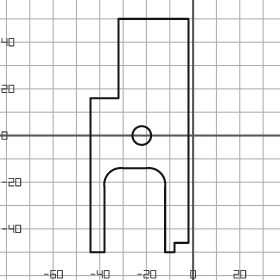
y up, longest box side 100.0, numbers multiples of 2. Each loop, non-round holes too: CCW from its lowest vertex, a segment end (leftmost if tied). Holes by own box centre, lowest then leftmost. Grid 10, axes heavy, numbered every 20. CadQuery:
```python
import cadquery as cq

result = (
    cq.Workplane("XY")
    .moveTo(-44.0, -50.0)
    .lineTo(-38.0, -50.0)
    .lineTo(-38.0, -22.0)
    .threePointArc((-36.0, -16.0), (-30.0, -14.0))
    .lineTo(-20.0, -14.0)
    .threePointArc((-14.0, -16.0), (-12.0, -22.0))
    .lineTo(-12.0, -50.0)
    .lineTo(-8.0, -50.0)
    .lineTo(-8.0, -46.0)
    .lineTo(-2.0, -46.0)
    .lineTo(-2.0, 50.0)
    .lineTo(-32.0, 50.0)
    .lineTo(-32.0, 16.0)
    .lineTo(-44.0, 16.0)
    .close()
    .moveTo(-22.0, 0.0)
    .circle(4.0)
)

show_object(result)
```